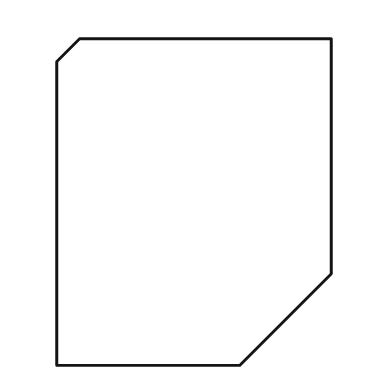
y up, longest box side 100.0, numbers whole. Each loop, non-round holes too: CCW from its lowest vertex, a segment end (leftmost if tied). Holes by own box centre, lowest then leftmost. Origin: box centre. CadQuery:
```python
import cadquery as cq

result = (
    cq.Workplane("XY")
    .moveTo(-42.0, -50.0)
    .lineTo(14.0, -50.0)
    .lineTo(42.0, -22.0)
    .lineTo(42.0, 50.0)
    .lineTo(-35.0, 50.0)
    .lineTo(-42.0, 43.0)
    .close()
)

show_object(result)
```